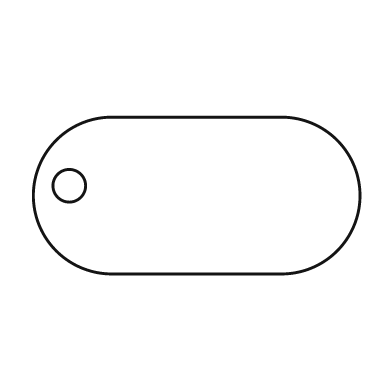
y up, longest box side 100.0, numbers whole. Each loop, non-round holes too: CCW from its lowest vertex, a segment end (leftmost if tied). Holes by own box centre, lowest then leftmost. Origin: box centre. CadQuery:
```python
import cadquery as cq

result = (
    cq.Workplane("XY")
    .moveTo(-26.0, -24.0)
    .lineTo(26.0, -24.0)
    .threePointArc((50.0, 0.0), (26.0, 24.0))
    .lineTo(-26.0, 24.0)
    .threePointArc((-50.0, 0.0), (-26.0, -24.0))
    .close()
    .moveTo(-39.0, 3.0)
    .circle(5.0)
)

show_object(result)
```